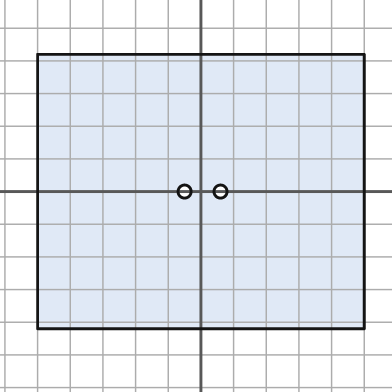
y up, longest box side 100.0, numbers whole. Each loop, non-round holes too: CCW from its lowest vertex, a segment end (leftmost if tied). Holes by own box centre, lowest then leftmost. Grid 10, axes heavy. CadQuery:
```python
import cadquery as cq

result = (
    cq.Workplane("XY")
    .moveTo(-50.0, -42.0)
    .lineTo(50.0, -42.0)
    .lineTo(50.0, 42.0)
    .lineTo(-50.0, 42.0)
    .close()
    .moveTo(-5.0, 0.0)
    .circle(2.0)
    .moveTo(6.0, 0.0)
    .circle(2.0)
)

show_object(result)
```